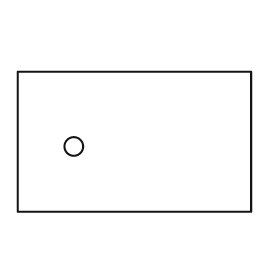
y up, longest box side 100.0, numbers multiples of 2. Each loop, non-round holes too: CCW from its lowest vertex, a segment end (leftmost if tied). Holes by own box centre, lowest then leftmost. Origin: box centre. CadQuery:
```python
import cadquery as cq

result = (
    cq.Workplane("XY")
    .moveTo(-50.0, -30.0)
    .lineTo(50.0, -30.0)
    .lineTo(50.0, 30.0)
    .lineTo(-50.0, 30.0)
    .close()
    .moveTo(-26.0, -2.0)
    .circle(4.0)
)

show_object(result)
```